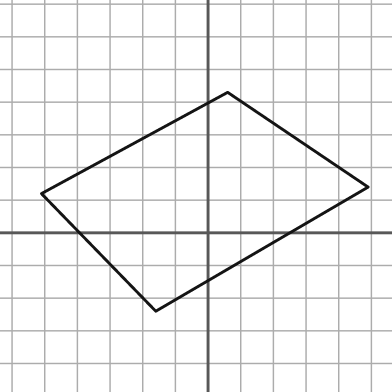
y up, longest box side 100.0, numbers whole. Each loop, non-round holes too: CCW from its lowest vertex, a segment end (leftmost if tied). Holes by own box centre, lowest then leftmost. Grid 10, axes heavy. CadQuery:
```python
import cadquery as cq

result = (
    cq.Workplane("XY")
    .moveTo(-16.0, -24.0)
    .lineTo(49.0, 14.0)
    .lineTo(6.0, 43.0)
    .lineTo(-51.0, 12.0)
    .close()
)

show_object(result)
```